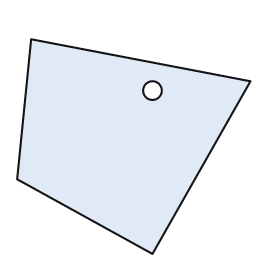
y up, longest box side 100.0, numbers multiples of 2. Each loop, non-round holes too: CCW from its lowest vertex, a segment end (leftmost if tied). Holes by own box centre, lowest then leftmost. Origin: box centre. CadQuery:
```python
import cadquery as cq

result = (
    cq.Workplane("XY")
    .moveTo(8.0, -46.0)
    .lineTo(50.0, 28.0)
    .lineTo(-44.0, 46.0)
    .lineTo(-50.0, -14.0)
    .close()
    .moveTo(8.0, 24.0)
    .circle(4.0)
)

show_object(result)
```